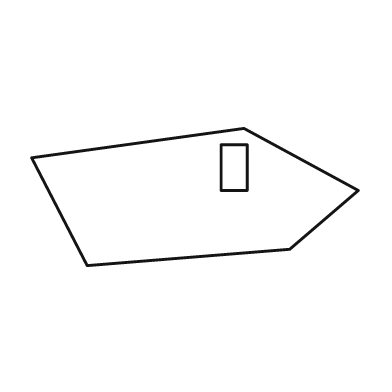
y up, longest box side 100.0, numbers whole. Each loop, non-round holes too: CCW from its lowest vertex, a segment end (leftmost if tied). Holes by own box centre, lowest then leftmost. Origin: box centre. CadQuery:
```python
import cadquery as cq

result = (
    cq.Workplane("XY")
    .moveTo(-33.0, -21.0)
    .lineTo(29.0, -16.0)
    .lineTo(50.0, 2.0)
    .lineTo(15.0, 21.0)
    .lineTo(-50.0, 12.0)
    .close()
    .moveTo(8.0, 2.0)
    .lineTo(16.0, 2.0)
    .lineTo(16.0, 16.0)
    .lineTo(8.0, 16.0)
    .close()
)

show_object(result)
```